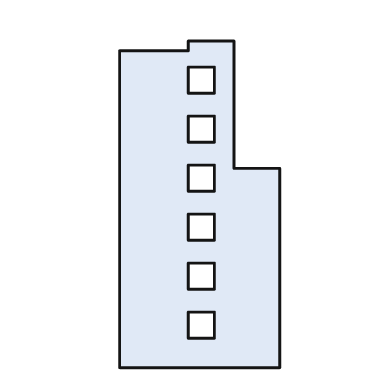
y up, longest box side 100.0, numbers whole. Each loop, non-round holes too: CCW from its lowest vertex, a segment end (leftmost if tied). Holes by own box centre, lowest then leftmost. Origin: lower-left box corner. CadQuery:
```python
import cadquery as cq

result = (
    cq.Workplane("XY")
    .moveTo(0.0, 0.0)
    .lineTo(49.0, 0.0)
    .lineTo(49.0, 61.0)
    .lineTo(35.0, 61.0)
    .lineTo(35.0, 100.0)
    .lineTo(21.0, 100.0)
    .lineTo(21.0, 97.0)
    .lineTo(0.0, 97.0)
    .close()
    .moveTo(21.0, 9.0)
    .lineTo(29.0, 9.0)
    .lineTo(29.0, 17.0)
    .lineTo(21.0, 17.0)
    .close()
    .moveTo(21.0, 24.0)
    .lineTo(29.0, 24.0)
    .lineTo(29.0, 32.0)
    .lineTo(21.0, 32.0)
    .close()
    .moveTo(21.0, 39.0)
    .lineTo(29.0, 39.0)
    .lineTo(29.0, 47.0)
    .lineTo(21.0, 47.0)
    .close()
    .moveTo(21.0, 54.0)
    .lineTo(29.0, 54.0)
    .lineTo(29.0, 62.0)
    .lineTo(21.0, 62.0)
    .close()
    .moveTo(21.0, 69.0)
    .lineTo(29.0, 69.0)
    .lineTo(29.0, 77.0)
    .lineTo(21.0, 77.0)
    .close()
    .moveTo(21.0, 84.0)
    .lineTo(29.0, 84.0)
    .lineTo(29.0, 92.0)
    .lineTo(21.0, 92.0)
    .close()
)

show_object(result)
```